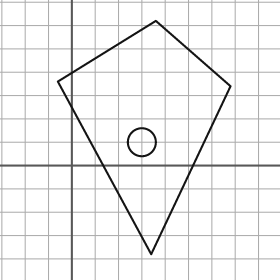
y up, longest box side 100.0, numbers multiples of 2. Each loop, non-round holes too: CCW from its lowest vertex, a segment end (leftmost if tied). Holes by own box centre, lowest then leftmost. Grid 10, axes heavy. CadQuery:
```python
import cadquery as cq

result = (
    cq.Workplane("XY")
    .moveTo(34.0, -38.0)
    .lineTo(68.0, 34.0)
    .lineTo(36.0, 62.0)
    .lineTo(-6.0, 36.0)
    .close()
    .moveTo(30.0, 10.0)
    .circle(6.0)
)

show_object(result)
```